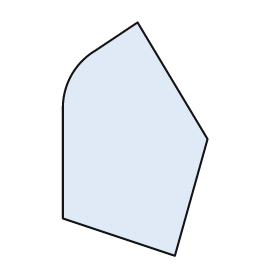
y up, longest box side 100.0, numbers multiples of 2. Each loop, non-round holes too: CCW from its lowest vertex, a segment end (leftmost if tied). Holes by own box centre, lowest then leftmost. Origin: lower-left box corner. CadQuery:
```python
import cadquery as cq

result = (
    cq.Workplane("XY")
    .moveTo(48.0, 0.0)
    .lineTo(62.0, 50.0)
    .lineTo(32.0, 100.0)
    .lineTo(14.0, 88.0)
    .threePointArc((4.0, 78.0), (0.0, 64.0))
    .lineTo(0.0, 16.0)
    .close()
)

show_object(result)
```